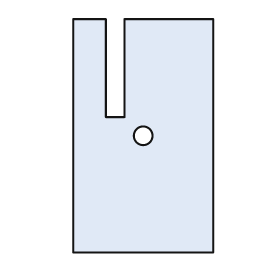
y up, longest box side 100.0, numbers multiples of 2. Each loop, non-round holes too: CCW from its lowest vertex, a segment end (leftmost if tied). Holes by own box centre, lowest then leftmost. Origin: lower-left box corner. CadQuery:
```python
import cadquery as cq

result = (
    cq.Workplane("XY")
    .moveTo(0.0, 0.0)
    .lineTo(60.0, 0.0)
    .lineTo(60.0, 100.0)
    .lineTo(22.0, 100.0)
    .lineTo(22.0, 58.0)
    .lineTo(14.0, 58.0)
    .lineTo(14.0, 100.0)
    .lineTo(0.0, 100.0)
    .close()
    .moveTo(30.0, 50.0)
    .circle(4.0)
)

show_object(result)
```